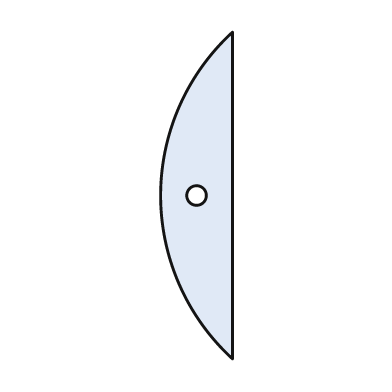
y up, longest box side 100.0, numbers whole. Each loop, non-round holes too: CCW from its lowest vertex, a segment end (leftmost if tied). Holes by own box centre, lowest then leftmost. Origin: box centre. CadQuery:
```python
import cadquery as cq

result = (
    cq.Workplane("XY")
    .moveTo(11.0, -50.0)
    .lineTo(11.0, 50.0)
    .threePointArc((-11.0, 0.0), (11.0, -50.0))
    .close()
    .moveTo(0.0, 0.0)
    .circle(3.0)
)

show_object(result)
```